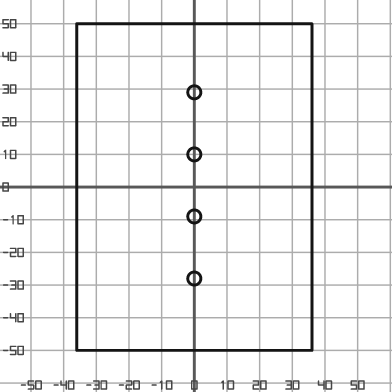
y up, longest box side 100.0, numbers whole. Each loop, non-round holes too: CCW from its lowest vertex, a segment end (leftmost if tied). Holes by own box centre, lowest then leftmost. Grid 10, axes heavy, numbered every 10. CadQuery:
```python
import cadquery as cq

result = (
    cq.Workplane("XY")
    .moveTo(-36.0, -50.0)
    .lineTo(36.0, -50.0)
    .lineTo(36.0, 50.0)
    .lineTo(-36.0, 50.0)
    .close()
    .moveTo(0.0, -28.0)
    .circle(2.0)
    .moveTo(0.0, -9.0)
    .circle(2.0)
    .moveTo(0.0, 10.0)
    .circle(2.0)
    .moveTo(0.0, 29.0)
    .circle(2.0)
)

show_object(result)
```